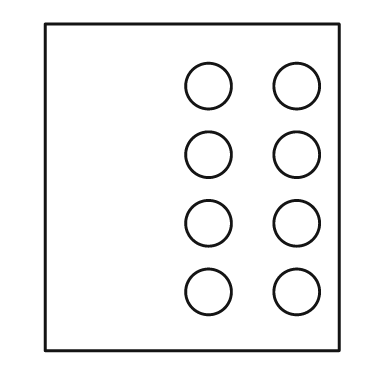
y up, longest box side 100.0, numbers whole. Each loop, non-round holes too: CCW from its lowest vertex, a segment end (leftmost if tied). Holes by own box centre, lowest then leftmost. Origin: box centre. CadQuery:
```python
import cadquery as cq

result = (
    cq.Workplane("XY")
    .moveTo(-45.0, -50.0)
    .lineTo(45.0, -50.0)
    .lineTo(45.0, 50.0)
    .lineTo(-45.0, 50.0)
    .close()
    .moveTo(5.0, -32.0)
    .circle(7.0)
    .moveTo(32.0, -32.0)
    .circle(7.0)
    .moveTo(5.0, -11.0)
    .circle(7.0)
    .moveTo(32.0, -11.0)
    .circle(7.0)
    .moveTo(5.0, 10.0)
    .circle(7.0)
    .moveTo(32.0, 10.0)
    .circle(7.0)
    .moveTo(5.0, 31.0)
    .circle(7.0)
    .moveTo(32.0, 31.0)
    .circle(7.0)
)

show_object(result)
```